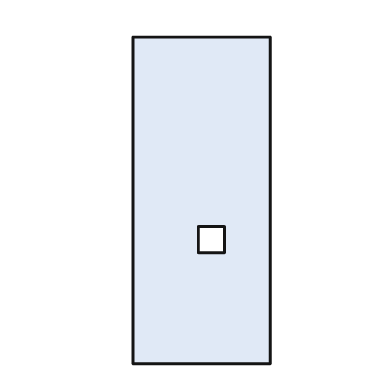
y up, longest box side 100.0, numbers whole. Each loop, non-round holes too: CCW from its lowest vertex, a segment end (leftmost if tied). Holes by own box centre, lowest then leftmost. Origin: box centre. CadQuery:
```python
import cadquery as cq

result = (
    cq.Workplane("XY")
    .moveTo(-21.0, -50.0)
    .lineTo(21.0, -50.0)
    .lineTo(21.0, 50.0)
    .lineTo(-21.0, 50.0)
    .close()
    .moveTo(-1.0, -16.0)
    .lineTo(7.0, -16.0)
    .lineTo(7.0, -8.0)
    .lineTo(-1.0, -8.0)
    .close()
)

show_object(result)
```